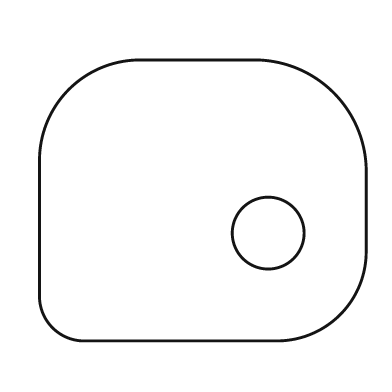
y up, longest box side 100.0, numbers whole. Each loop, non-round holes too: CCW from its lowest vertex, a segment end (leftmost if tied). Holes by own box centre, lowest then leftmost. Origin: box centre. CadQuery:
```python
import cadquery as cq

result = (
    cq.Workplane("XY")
    .moveTo(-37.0, -43.0)
    .lineTo(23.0, -43.0)
    .threePointArc((42.0, -35.0), (50.0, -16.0))
    .lineTo(50.0, 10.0)
    .threePointArc((40.0, 33.0), (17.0, 43.0))
    .lineTo(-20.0, 43.0)
    .threePointArc((-41.0, 34.0), (-50.0, 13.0))
    .lineTo(-50.0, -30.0)
    .threePointArc((-46.0, -39.0), (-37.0, -43.0))
    .close()
    .moveTo(20.0, -10.0)
    .circle(11.0)
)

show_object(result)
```